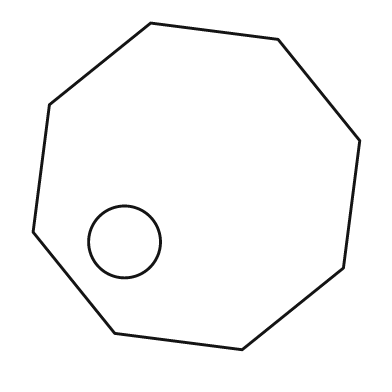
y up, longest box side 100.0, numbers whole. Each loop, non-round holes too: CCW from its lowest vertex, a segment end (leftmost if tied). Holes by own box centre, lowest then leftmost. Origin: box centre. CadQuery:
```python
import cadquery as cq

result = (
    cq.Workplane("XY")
    .moveTo(14.0, -50.0)
    .lineTo(45.0, -25.0)
    .lineTo(50.0, 14.0)
    .lineTo(25.0, 45.0)
    .lineTo(-14.0, 50.0)
    .lineTo(-45.0, 25.0)
    .lineTo(-50.0, -14.0)
    .lineTo(-25.0, -45.0)
    .close()
    .moveTo(-22.0, -17.0)
    .circle(11.0)
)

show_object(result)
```